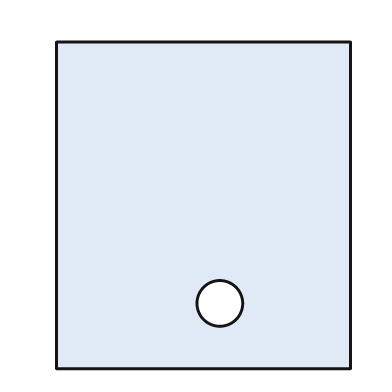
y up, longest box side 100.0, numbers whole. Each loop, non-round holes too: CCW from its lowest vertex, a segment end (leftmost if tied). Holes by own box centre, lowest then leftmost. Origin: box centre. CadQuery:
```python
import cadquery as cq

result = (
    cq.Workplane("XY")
    .moveTo(-45.0, -50.0)
    .lineTo(45.0, -50.0)
    .lineTo(45.0, 50.0)
    .lineTo(-45.0, 50.0)
    .close()
    .moveTo(5.0, -30.0)
    .circle(7.0)
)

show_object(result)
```